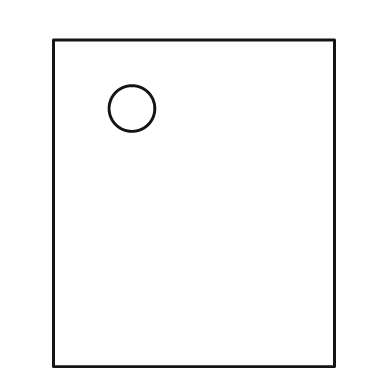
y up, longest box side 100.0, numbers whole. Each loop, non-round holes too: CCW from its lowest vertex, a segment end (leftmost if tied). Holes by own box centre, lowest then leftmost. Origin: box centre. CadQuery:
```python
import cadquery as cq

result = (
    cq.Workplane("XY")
    .moveTo(-43.0, -50.0)
    .lineTo(43.0, -50.0)
    .lineTo(43.0, 50.0)
    .lineTo(-43.0, 50.0)
    .close()
    .moveTo(-19.0, 29.0)
    .circle(7.0)
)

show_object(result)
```